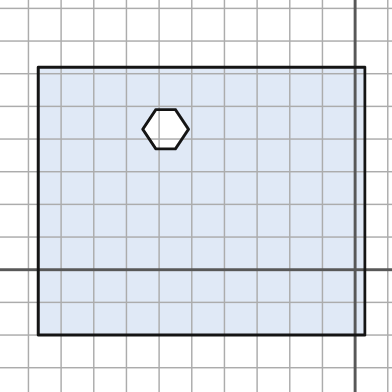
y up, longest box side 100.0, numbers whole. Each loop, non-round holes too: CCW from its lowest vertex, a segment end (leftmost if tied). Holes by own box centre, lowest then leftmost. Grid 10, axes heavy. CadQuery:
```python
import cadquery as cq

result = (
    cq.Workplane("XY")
    .moveTo(-97.0, -20.0)
    .lineTo(3.0, -20.0)
    .lineTo(3.0, 62.0)
    .lineTo(-97.0, 62.0)
    .close()
    .moveTo(-61.0, 37.0)
    .lineTo(-55.0, 37.0)
    .lineTo(-51.0, 43.0)
    .lineTo(-55.0, 49.0)
    .lineTo(-61.0, 49.0)
    .lineTo(-65.0, 43.0)
    .close()
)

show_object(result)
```